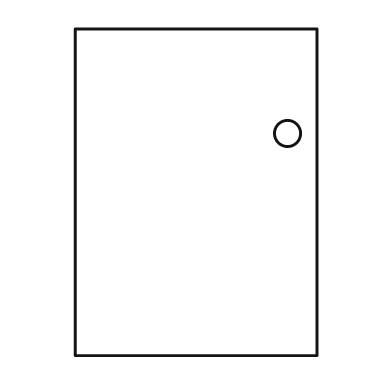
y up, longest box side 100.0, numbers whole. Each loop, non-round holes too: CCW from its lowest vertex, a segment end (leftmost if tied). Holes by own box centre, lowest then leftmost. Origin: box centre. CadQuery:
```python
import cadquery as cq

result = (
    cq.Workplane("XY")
    .moveTo(-37.0, -50.0)
    .lineTo(37.0, -50.0)
    .lineTo(37.0, 50.0)
    .lineTo(-37.0, 50.0)
    .close()
    .moveTo(28.0, 18.0)
    .circle(4.0)
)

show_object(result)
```